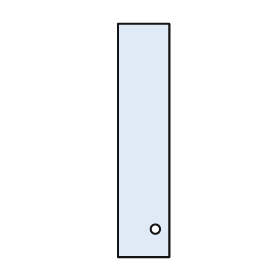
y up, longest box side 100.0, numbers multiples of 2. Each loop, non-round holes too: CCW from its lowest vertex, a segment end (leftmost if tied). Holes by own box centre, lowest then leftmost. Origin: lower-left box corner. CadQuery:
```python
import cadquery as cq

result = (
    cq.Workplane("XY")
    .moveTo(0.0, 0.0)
    .lineTo(22.0, 0.0)
    .lineTo(22.0, 100.0)
    .lineTo(0.0, 100.0)
    .close()
    .moveTo(16.0, 12.0)
    .circle(2.0)
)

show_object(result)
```